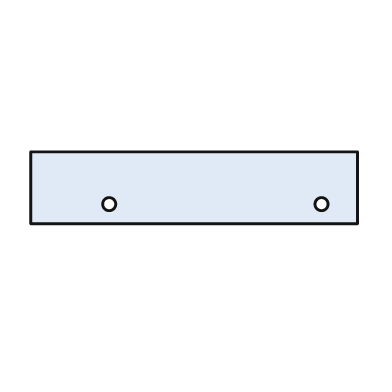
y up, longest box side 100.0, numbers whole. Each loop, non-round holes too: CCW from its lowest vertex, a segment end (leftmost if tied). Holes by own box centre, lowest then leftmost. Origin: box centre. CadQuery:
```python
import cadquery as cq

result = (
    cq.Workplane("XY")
    .moveTo(-50.0, -11.0)
    .lineTo(50.0, -11.0)
    .lineTo(50.0, 11.0)
    .lineTo(-50.0, 11.0)
    .close()
    .moveTo(-26.0, -5.0)
    .circle(2.0)
    .moveTo(39.0, -5.0)
    .circle(2.0)
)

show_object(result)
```